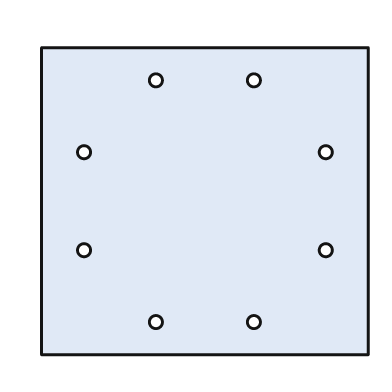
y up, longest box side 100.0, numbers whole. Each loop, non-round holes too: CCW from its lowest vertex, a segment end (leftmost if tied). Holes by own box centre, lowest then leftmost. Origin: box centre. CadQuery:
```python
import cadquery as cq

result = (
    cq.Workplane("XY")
    .moveTo(-50.0, -47.0)
    .lineTo(50.0, -47.0)
    .lineTo(50.0, 47.0)
    .lineTo(-50.0, 47.0)
    .close()
    .moveTo(-15.0, -37.0)
    .circle(2.0)
    .moveTo(15.0, -37.0)
    .circle(2.0)
    .moveTo(-37.0, -15.0)
    .circle(2.0)
    .moveTo(37.0, -15.0)
    .circle(2.0)
    .moveTo(-37.0, 15.0)
    .circle(2.0)
    .moveTo(37.0, 15.0)
    .circle(2.0)
    .moveTo(-15.0, 37.0)
    .circle(2.0)
    .moveTo(15.0, 37.0)
    .circle(2.0)
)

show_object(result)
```